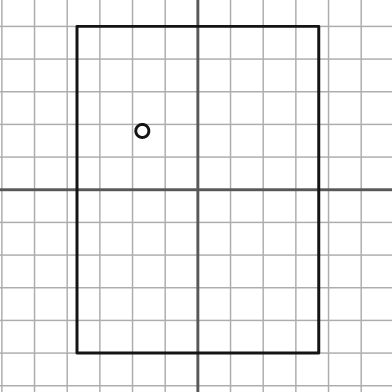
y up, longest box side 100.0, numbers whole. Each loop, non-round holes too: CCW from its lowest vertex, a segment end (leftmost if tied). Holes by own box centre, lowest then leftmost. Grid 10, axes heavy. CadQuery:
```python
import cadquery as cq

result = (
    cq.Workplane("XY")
    .moveTo(-37.0, -50.0)
    .lineTo(37.0, -50.0)
    .lineTo(37.0, 50.0)
    .lineTo(-37.0, 50.0)
    .close()
    .moveTo(-17.0, 18.0)
    .circle(2.0)
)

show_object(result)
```